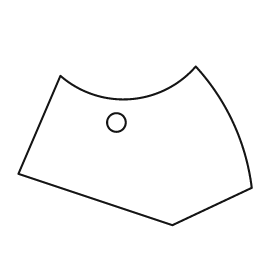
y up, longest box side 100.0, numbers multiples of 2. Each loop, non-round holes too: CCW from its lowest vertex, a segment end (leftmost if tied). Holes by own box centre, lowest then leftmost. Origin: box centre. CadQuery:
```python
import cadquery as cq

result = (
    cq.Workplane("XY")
    .moveTo(16.0, -34.0)
    .lineTo(50.0, -18.0)
    .threePointArc((42.0, 10.0), (26.0, 34.0))
    .threePointArc((-2.0, 20.0), (-32.0, 30.0))
    .lineTo(-50.0, -12.0)
    .close()
    .moveTo(-8.0, 10.0)
    .circle(4.0)
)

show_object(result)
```